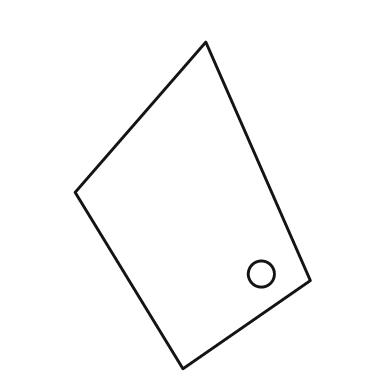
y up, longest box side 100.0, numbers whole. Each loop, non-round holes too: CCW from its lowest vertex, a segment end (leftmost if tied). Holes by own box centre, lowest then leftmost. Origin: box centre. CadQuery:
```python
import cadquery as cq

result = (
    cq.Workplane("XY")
    .moveTo(-3.0, -50.0)
    .lineTo(36.0, -23.0)
    .lineTo(4.0, 50.0)
    .lineTo(-36.0, 4.0)
    .close()
    .moveTo(21.0, -21.0)
    .circle(4.0)
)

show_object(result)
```